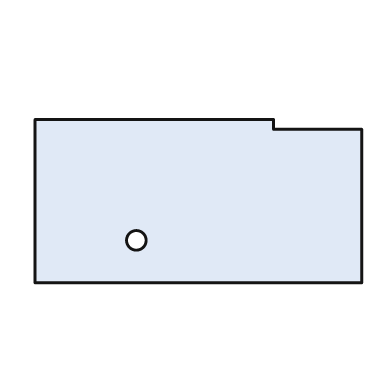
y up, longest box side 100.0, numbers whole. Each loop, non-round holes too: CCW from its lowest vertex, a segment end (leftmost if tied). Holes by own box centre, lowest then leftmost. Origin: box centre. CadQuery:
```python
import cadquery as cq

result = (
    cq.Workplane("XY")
    .moveTo(-50.0, -25.0)
    .lineTo(50.0, -25.0)
    .lineTo(50.0, 22.0)
    .lineTo(23.0, 22.0)
    .lineTo(23.0, 25.0)
    .lineTo(-50.0, 25.0)
    .close()
    .moveTo(-19.0, -12.0)
    .circle(3.0)
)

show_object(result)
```